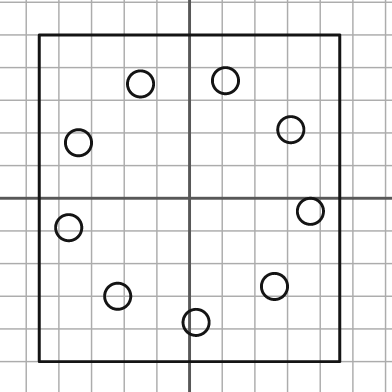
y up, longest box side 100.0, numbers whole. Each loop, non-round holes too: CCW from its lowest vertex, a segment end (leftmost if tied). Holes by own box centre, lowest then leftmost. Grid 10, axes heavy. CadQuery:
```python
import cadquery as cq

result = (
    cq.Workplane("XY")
    .moveTo(-46.0, -50.0)
    .lineTo(46.0, -50.0)
    .lineTo(46.0, 50.0)
    .lineTo(-46.0, 50.0)
    .close()
    .moveTo(2.0, -38.0)
    .circle(4.0)
    .moveTo(-22.0, -30.0)
    .circle(4.0)
    .moveTo(26.0, -27.0)
    .circle(4.0)
    .moveTo(-37.0, -9.0)
    .circle(4.0)
    .moveTo(37.0, -4.0)
    .circle(4.0)
    .moveTo(-34.0, 17.0)
    .circle(4.0)
    .moveTo(31.0, 21.0)
    .circle(4.0)
    .moveTo(-15.0, 35.0)
    .circle(4.0)
    .moveTo(11.0, 36.0)
    .circle(4.0)
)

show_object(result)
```